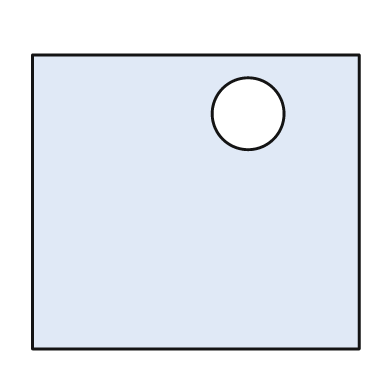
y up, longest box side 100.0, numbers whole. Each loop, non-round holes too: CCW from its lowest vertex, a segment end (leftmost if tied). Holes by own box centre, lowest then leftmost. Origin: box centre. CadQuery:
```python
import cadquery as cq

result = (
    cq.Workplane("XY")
    .moveTo(-50.0, -45.0)
    .lineTo(50.0, -45.0)
    .lineTo(50.0, 45.0)
    .lineTo(-50.0, 45.0)
    .close()
    .moveTo(16.0, 27.0)
    .circle(11.0)
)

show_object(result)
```